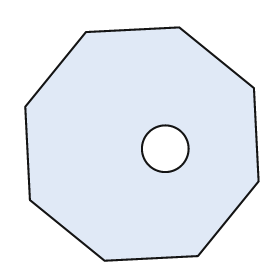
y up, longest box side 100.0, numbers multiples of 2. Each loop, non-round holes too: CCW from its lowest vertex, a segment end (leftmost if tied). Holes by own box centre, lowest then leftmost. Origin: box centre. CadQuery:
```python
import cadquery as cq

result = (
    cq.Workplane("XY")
    .moveTo(-16.0, -50.0)
    .lineTo(24.0, -48.0)
    .lineTo(50.0, -16.0)
    .lineTo(48.0, 24.0)
    .lineTo(16.0, 50.0)
    .lineTo(-24.0, 48.0)
    .lineTo(-50.0, 16.0)
    .lineTo(-48.0, -24.0)
    .close()
    .moveTo(10.0, -2.0)
    .circle(10.0)
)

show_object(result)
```